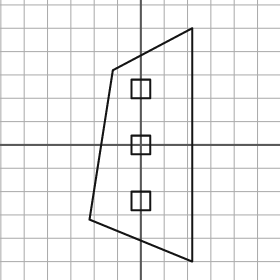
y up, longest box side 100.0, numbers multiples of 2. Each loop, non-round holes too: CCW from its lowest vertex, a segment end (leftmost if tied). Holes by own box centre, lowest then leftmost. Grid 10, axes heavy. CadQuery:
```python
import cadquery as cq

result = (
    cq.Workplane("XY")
    .moveTo(22.0, -50.0)
    .lineTo(22.0, 50.0)
    .lineTo(-12.0, 32.0)
    .lineTo(-22.0, -32.0)
    .close()
    .moveTo(-4.0, -28.0)
    .lineTo(4.0, -28.0)
    .lineTo(4.0, -20.0)
    .lineTo(-4.0, -20.0)
    .close()
    .moveTo(-4.0, -4.0)
    .lineTo(4.0, -4.0)
    .lineTo(4.0, 4.0)
    .lineTo(-4.0, 4.0)
    .close()
    .moveTo(-4.0, 20.0)
    .lineTo(4.0, 20.0)
    .lineTo(4.0, 28.0)
    .lineTo(-4.0, 28.0)
    .close()
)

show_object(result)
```